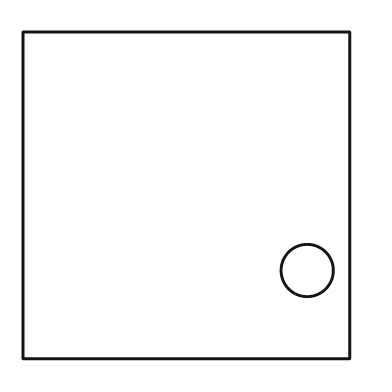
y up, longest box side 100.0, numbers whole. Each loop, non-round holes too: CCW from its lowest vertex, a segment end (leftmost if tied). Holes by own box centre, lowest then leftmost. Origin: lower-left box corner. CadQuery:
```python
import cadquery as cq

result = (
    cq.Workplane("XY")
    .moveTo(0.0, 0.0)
    .lineTo(100.0, 0.0)
    .lineTo(100.0, 100.0)
    .lineTo(0.0, 100.0)
    .close()
    .moveTo(87.0, 27.0)
    .circle(8.0)
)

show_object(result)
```